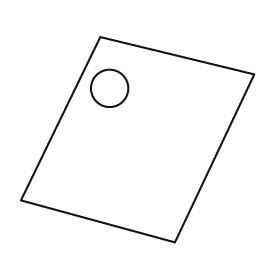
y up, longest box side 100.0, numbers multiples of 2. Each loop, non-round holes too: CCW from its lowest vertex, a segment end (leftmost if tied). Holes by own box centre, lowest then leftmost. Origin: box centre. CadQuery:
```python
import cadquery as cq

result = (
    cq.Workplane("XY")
    .moveTo(16.0, -44.0)
    .lineTo(50.0, 28.0)
    .lineTo(-16.0, 44.0)
    .lineTo(-50.0, -26.0)
    .close()
    .moveTo(-12.0, 22.0)
    .circle(8.0)
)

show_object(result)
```